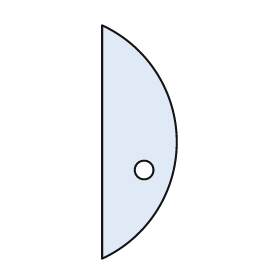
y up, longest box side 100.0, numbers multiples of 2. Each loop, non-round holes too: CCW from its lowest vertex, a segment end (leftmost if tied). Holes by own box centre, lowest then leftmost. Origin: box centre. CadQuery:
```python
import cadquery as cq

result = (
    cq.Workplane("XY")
    .moveTo(-16.0, -50.0)
    .threePointArc((16.0, 0.0), (-16.0, 50.0))
    .close()
    .moveTo(2.0, -12.0)
    .circle(4.0)
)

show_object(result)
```